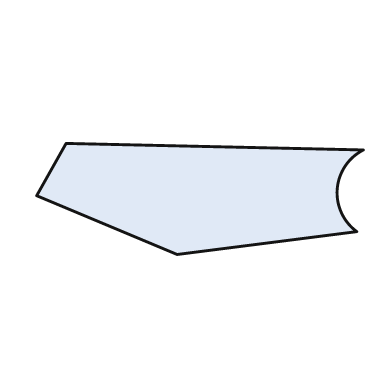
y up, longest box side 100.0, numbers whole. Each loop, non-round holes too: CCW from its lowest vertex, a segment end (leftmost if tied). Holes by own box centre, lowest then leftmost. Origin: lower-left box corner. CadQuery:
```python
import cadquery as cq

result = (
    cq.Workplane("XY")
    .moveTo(43.0, 0.0)
    .lineTo(98.0, 7.0)
    .threePointArc((92.0, 20.0), (100.0, 32.0))
    .lineTo(9.0, 34.0)
    .lineTo(0.0, 18.0)
    .close()
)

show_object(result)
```